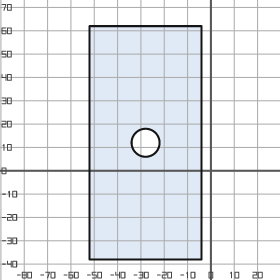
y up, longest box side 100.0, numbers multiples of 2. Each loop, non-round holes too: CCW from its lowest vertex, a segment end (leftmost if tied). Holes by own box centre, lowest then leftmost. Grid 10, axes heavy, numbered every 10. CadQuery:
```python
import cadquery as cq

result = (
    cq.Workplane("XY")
    .moveTo(-52.0, -38.0)
    .lineTo(-4.0, -38.0)
    .lineTo(-4.0, 62.0)
    .lineTo(-52.0, 62.0)
    .close()
    .moveTo(-28.0, 12.0)
    .circle(6.0)
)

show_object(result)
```